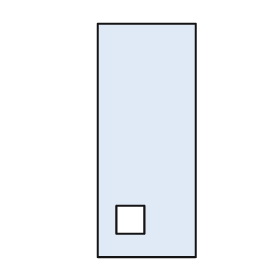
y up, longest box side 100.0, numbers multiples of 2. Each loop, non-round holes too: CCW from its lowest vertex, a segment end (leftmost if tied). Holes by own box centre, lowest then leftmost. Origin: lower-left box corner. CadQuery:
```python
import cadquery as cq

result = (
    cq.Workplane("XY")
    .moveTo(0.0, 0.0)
    .lineTo(42.0, 0.0)
    .lineTo(42.0, 100.0)
    .lineTo(0.0, 100.0)
    .close()
    .moveTo(8.0, 10.0)
    .lineTo(20.0, 10.0)
    .lineTo(20.0, 22.0)
    .lineTo(8.0, 22.0)
    .close()
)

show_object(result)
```